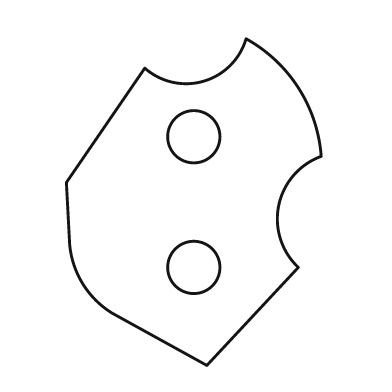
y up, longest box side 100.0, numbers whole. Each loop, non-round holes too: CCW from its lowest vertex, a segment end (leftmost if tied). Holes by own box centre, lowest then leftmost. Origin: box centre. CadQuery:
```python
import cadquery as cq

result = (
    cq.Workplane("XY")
    .moveTo(4.0, -50.0)
    .lineTo(32.0, -20.0)
    .threePointArc((26.0, -1.0), (39.0, 14.0))
    .threePointArc((32.0, 35.0), (16.0, 50.0))
    .threePointArc((3.0, 37.0), (-15.0, 41.0))
    .lineTo(-39.0, 6.0)
    .lineTo(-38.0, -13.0)
    .threePointArc((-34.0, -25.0), (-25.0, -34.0))
    .close()
    .moveTo(0.0, -20.0)
    .circle(8.0)
    .moveTo(0.0, 20.0)
    .circle(8.0)
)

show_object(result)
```